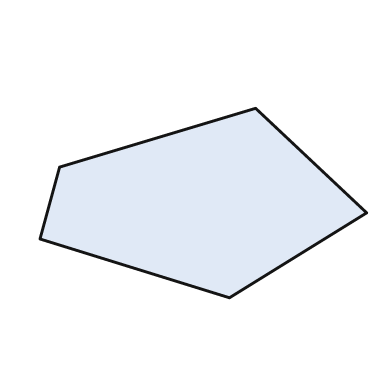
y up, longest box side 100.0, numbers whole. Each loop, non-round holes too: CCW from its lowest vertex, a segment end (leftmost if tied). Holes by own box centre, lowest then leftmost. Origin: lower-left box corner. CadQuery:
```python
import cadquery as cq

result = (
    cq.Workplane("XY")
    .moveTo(58.0, 0.0)
    .lineTo(100.0, 26.0)
    .lineTo(66.0, 58.0)
    .lineTo(6.0, 40.0)
    .lineTo(0.0, 18.0)
    .close()
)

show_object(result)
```